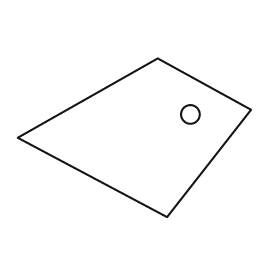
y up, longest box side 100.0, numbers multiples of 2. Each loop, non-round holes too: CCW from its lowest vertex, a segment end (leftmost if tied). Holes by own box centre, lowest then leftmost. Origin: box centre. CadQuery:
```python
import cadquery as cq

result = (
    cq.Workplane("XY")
    .moveTo(14.0, -34.0)
    .lineTo(50.0, 12.0)
    .lineTo(10.0, 34.0)
    .lineTo(-50.0, 0.0)
    .close()
    .moveTo(24.0, 10.0)
    .circle(4.0)
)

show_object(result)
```